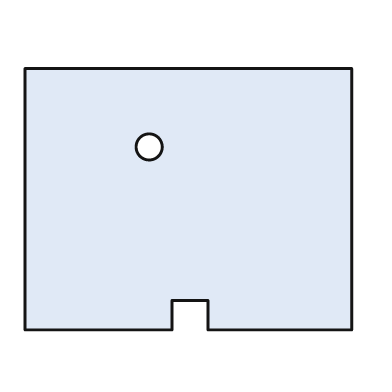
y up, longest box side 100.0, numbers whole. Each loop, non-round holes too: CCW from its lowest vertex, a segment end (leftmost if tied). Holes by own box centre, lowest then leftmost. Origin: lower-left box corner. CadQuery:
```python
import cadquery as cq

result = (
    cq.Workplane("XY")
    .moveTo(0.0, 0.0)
    .lineTo(45.0, 0.0)
    .lineTo(45.0, 9.0)
    .lineTo(56.0, 9.0)
    .lineTo(56.0, 0.0)
    .lineTo(100.0, 0.0)
    .lineTo(100.0, 80.0)
    .lineTo(0.0, 80.0)
    .close()
    .moveTo(38.0, 56.0)
    .circle(4.0)
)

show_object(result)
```